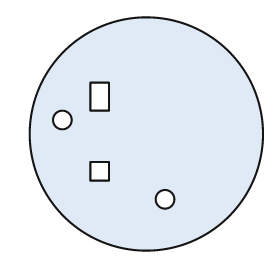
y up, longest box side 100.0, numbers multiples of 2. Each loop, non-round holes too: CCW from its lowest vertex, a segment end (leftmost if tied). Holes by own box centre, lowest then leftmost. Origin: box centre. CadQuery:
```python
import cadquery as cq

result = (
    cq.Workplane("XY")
    .moveTo(0.0, 0.0)
    .circle(50.0)
    .moveTo(8.0, -28.0)
    .circle(4.0)
    .moveTo(-24.0, -20.0)
    .lineTo(-16.0, -20.0)
    .lineTo(-16.0, -12.0)
    .lineTo(-24.0, -12.0)
    .close()
    .moveTo(-36.0, 6.0)
    .circle(4.0)
    .moveTo(-24.0, 10.0)
    .lineTo(-16.0, 10.0)
    .lineTo(-16.0, 22.0)
    .lineTo(-24.0, 22.0)
    .close()
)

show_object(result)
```